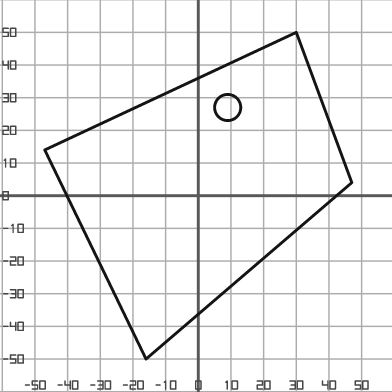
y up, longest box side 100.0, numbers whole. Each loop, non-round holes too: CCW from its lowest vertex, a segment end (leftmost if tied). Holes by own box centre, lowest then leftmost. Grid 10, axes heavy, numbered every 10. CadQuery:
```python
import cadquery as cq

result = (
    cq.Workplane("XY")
    .moveTo(-16.0, -50.0)
    .lineTo(47.0, 4.0)
    .lineTo(30.0, 50.0)
    .lineTo(-47.0, 14.0)
    .close()
    .moveTo(9.0, 27.0)
    .circle(4.0)
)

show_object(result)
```